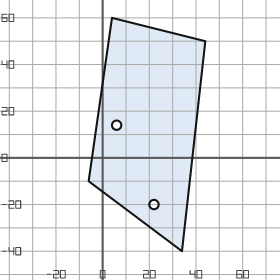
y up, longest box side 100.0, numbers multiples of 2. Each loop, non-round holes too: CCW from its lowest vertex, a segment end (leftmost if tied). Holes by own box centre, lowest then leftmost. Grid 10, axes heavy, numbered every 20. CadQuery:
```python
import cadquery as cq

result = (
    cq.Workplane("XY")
    .moveTo(34.0, -40.0)
    .lineTo(44.0, 50.0)
    .lineTo(4.0, 60.0)
    .lineTo(-6.0, -10.0)
    .close()
    .moveTo(22.0, -20.0)
    .circle(2.0)
    .moveTo(6.0, 14.0)
    .circle(2.0)
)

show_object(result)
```